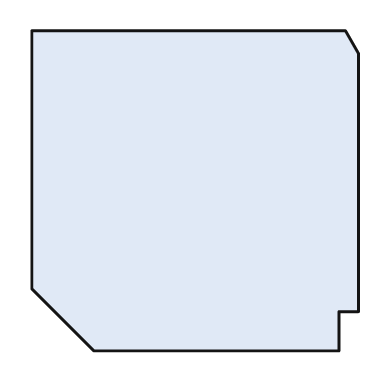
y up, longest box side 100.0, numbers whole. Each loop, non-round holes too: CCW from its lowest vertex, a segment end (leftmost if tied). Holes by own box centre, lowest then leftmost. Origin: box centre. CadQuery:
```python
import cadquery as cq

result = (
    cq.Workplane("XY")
    .moveTo(-31.0, -49.0)
    .lineTo(44.0, -49.0)
    .lineTo(44.0, -37.0)
    .lineTo(50.0, -37.0)
    .lineTo(50.0, 42.0)
    .lineTo(46.0, 49.0)
    .lineTo(-50.0, 49.0)
    .lineTo(-50.0, -30.0)
    .close()
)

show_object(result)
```